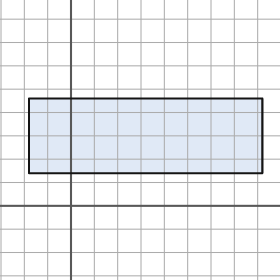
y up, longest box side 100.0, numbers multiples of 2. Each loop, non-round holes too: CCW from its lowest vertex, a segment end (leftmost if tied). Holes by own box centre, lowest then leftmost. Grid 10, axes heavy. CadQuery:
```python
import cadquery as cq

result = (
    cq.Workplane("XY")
    .moveTo(-18.0, 14.0)
    .lineTo(82.0, 14.0)
    .lineTo(82.0, 46.0)
    .lineTo(-18.0, 46.0)
    .close()
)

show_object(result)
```